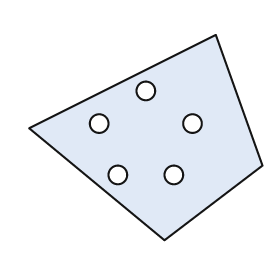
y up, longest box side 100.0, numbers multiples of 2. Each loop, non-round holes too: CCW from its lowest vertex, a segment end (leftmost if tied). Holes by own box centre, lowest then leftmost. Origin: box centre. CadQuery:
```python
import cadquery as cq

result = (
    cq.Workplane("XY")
    .moveTo(8.0, -44.0)
    .lineTo(50.0, -12.0)
    .lineTo(30.0, 44.0)
    .lineTo(-50.0, 4.0)
    .close()
    .moveTo(-12.0, -16.0)
    .circle(4.0)
    .moveTo(12.0, -16.0)
    .circle(4.0)
    .moveTo(-20.0, 6.0)
    .circle(4.0)
    .moveTo(20.0, 6.0)
    .circle(4.0)
    .moveTo(0.0, 20.0)
    .circle(4.0)
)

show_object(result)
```